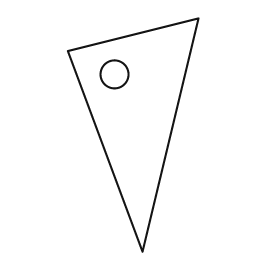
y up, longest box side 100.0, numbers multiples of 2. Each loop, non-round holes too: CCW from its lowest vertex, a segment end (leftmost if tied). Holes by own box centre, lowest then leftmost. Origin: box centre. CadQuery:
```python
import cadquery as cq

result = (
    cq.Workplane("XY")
    .moveTo(4.0, -50.0)
    .lineTo(28.0, 50.0)
    .lineTo(-28.0, 36.0)
    .close()
    .moveTo(-8.0, 26.0)
    .circle(6.0)
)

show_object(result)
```